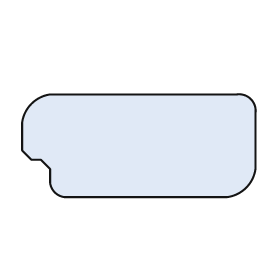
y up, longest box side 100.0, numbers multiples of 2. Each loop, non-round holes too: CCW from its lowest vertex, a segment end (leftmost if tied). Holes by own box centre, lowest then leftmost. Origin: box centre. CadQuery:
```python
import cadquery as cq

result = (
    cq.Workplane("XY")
    .moveTo(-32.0, -22.0)
    .lineTo(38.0, -22.0)
    .threePointArc((46.0, -18.0), (50.0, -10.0))
    .lineTo(50.0, 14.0)
    .threePointArc((48.0, 20.0), (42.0, 22.0))
    .lineTo(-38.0, 22.0)
    .threePointArc((-46.0, 18.0), (-50.0, 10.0))
    .lineTo(-50.0, -2.0)
    .lineTo(-46.0, -6.0)
    .lineTo(-42.0, -6.0)
    .lineTo(-38.0, -10.0)
    .lineTo(-38.0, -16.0)
    .threePointArc((-36.0, -20.0), (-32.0, -22.0))
    .close()
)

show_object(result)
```